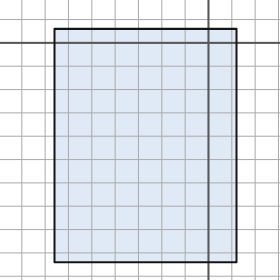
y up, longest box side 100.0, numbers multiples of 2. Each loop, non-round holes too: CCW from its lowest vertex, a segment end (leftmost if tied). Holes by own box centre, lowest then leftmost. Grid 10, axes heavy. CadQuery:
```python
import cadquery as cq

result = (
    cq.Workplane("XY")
    .moveTo(-66.0, -94.0)
    .lineTo(12.0, -94.0)
    .lineTo(12.0, 6.0)
    .lineTo(-66.0, 6.0)
    .close()
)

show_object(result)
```